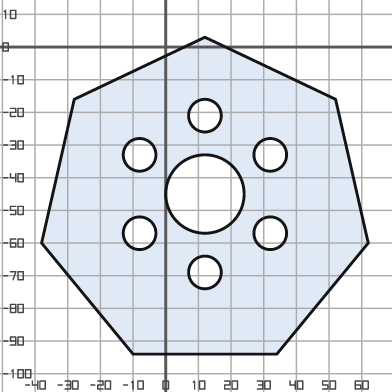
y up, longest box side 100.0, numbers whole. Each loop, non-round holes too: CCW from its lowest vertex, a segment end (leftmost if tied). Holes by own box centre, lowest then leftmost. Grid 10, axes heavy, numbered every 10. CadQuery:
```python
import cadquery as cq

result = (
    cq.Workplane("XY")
    .moveTo(-10.0, -94.0)
    .lineTo(34.0, -94.0)
    .lineTo(62.0, -60.0)
    .lineTo(52.0, -16.0)
    .lineTo(12.0, 3.0)
    .lineTo(-28.0, -16.0)
    .lineTo(-38.0, -60.0)
    .close()
    .moveTo(12.0, -69.0)
    .circle(5.0)
    .moveTo(-8.0, -57.0)
    .circle(5.0)
    .moveTo(32.0, -57.0)
    .circle(5.0)
    .moveTo(12.0, -45.0)
    .circle(12.0)
    .moveTo(-8.0, -33.0)
    .circle(5.0)
    .moveTo(32.0, -33.0)
    .circle(5.0)
    .moveTo(12.0, -21.0)
    .circle(5.0)
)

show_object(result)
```